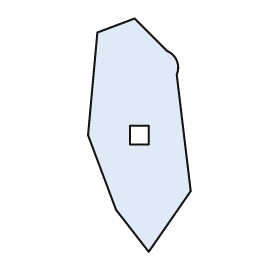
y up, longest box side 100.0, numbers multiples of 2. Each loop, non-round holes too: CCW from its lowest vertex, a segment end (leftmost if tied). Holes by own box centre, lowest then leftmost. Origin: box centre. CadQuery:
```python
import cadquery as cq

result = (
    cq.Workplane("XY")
    .moveTo(4.0, -50.0)
    .lineTo(22.0, -24.0)
    .lineTo(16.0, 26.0)
    .threePointArc((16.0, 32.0), (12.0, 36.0))
    .lineTo(-2.0, 50.0)
    .lineTo(-18.0, 44.0)
    .lineTo(-22.0, 0.0)
    .lineTo(-10.0, -32.0)
    .close()
    .moveTo(-4.0, -4.0)
    .lineTo(4.0, -4.0)
    .lineTo(4.0, 4.0)
    .lineTo(-4.0, 4.0)
    .close()
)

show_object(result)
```